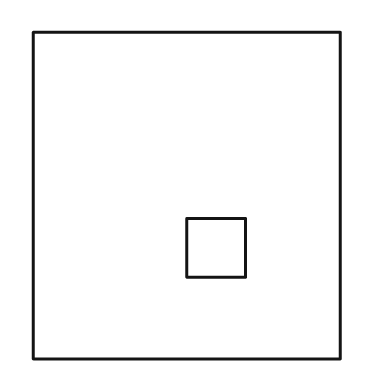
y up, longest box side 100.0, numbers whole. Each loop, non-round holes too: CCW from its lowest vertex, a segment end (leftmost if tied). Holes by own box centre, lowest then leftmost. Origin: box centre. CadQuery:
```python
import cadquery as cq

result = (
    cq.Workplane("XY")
    .moveTo(-47.0, -50.0)
    .lineTo(47.0, -50.0)
    .lineTo(47.0, 50.0)
    .lineTo(-47.0, 50.0)
    .close()
    .moveTo(0.0, -25.0)
    .lineTo(18.0, -25.0)
    .lineTo(18.0, -7.0)
    .lineTo(0.0, -7.0)
    .close()
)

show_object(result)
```